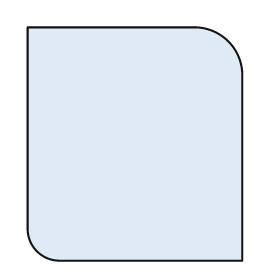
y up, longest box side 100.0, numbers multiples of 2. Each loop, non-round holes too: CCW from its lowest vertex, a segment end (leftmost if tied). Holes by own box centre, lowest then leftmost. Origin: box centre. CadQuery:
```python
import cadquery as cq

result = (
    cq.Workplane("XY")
    .moveTo(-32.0, -50.0)
    .lineTo(46.0, -50.0)
    .lineTo(46.0, 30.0)
    .threePointArc((40.0, 44.0), (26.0, 50.0))
    .lineTo(-46.0, 50.0)
    .lineTo(-46.0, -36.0)
    .threePointArc((-42.0, -46.0), (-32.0, -50.0))
    .close()
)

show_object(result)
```